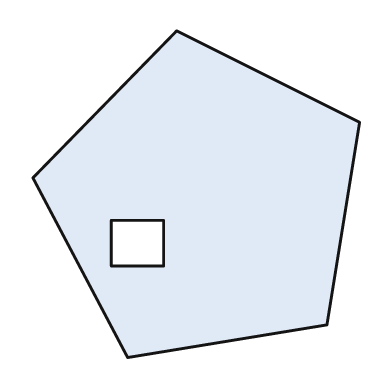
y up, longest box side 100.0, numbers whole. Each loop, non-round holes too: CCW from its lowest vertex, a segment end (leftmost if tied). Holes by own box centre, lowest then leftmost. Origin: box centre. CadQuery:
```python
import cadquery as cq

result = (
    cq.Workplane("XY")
    .moveTo(-21.0, -50.0)
    .lineTo(40.0, -40.0)
    .lineTo(50.0, 22.0)
    .lineTo(-6.0, 50.0)
    .lineTo(-50.0, 5.0)
    .close()
    .moveTo(-26.0, -22.0)
    .lineTo(-10.0, -22.0)
    .lineTo(-10.0, -8.0)
    .lineTo(-26.0, -8.0)
    .close()
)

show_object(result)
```